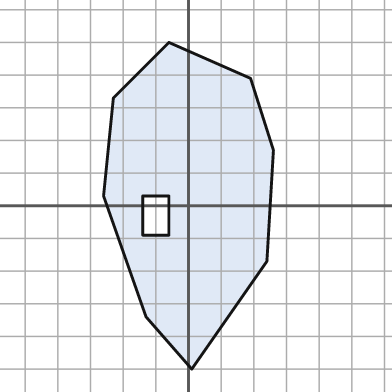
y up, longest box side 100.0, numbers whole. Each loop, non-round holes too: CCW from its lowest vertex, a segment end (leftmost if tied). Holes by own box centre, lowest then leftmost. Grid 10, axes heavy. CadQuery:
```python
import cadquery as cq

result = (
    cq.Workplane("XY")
    .moveTo(1.0, -50.0)
    .lineTo(24.0, -17.0)
    .lineTo(26.0, 17.0)
    .lineTo(19.0, 39.0)
    .lineTo(-6.0, 50.0)
    .lineTo(-23.0, 33.0)
    .lineTo(-26.0, 3.0)
    .lineTo(-13.0, -34.0)
    .close()
    .moveTo(-14.0, -9.0)
    .lineTo(-6.0, -9.0)
    .lineTo(-6.0, 3.0)
    .lineTo(-14.0, 3.0)
    .close()
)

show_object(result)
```